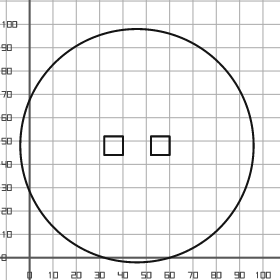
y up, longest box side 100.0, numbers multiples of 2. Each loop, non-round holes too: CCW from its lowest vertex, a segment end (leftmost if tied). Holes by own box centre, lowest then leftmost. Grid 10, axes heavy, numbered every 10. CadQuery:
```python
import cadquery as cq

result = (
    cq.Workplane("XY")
    .moveTo(46.0, 48.0)
    .circle(50.0)
    .moveTo(32.0, 44.0)
    .lineTo(40.0, 44.0)
    .lineTo(40.0, 52.0)
    .lineTo(32.0, 52.0)
    .close()
    .moveTo(52.0, 44.0)
    .lineTo(60.0, 44.0)
    .lineTo(60.0, 52.0)
    .lineTo(52.0, 52.0)
    .close()
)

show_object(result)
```